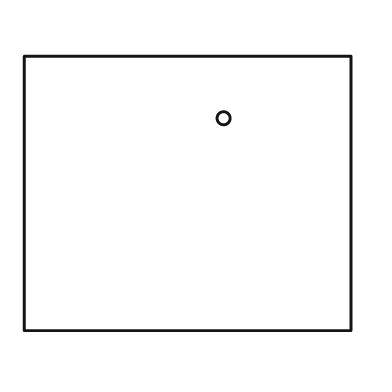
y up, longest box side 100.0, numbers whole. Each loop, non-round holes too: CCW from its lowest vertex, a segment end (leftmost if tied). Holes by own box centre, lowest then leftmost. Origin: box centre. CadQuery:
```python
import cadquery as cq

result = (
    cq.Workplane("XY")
    .moveTo(-50.0, -42.0)
    .lineTo(50.0, -42.0)
    .lineTo(50.0, 42.0)
    .lineTo(-50.0, 42.0)
    .close()
    .moveTo(11.0, 23.0)
    .circle(2.0)
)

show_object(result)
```